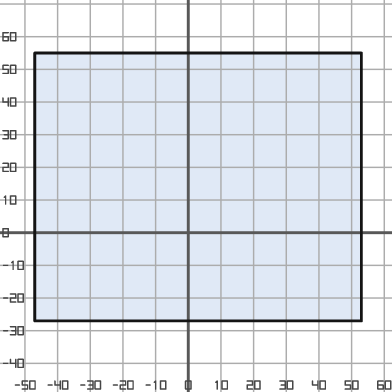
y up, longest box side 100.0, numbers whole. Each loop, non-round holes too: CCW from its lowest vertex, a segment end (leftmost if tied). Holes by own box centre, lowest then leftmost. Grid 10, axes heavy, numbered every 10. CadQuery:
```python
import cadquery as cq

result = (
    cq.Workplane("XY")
    .moveTo(-47.0, -27.0)
    .lineTo(53.0, -27.0)
    .lineTo(53.0, 55.0)
    .lineTo(-47.0, 55.0)
    .close()
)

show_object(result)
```